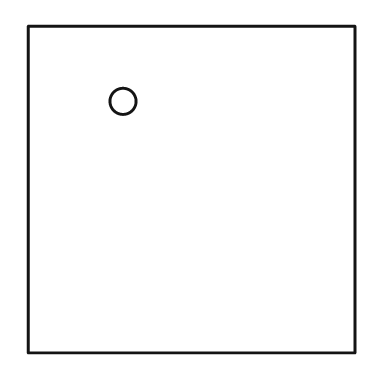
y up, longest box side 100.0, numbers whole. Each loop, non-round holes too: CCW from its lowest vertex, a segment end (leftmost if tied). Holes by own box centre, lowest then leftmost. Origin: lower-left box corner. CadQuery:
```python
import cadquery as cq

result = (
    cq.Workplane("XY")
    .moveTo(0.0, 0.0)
    .lineTo(100.0, 0.0)
    .lineTo(100.0, 100.0)
    .lineTo(0.0, 100.0)
    .close()
    .moveTo(29.0, 77.0)
    .circle(4.0)
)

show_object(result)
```